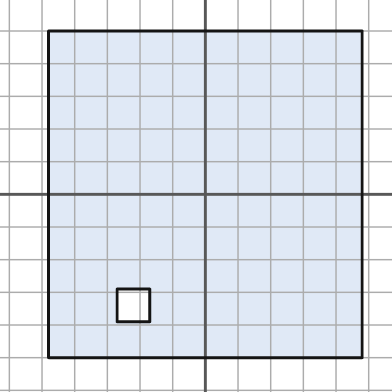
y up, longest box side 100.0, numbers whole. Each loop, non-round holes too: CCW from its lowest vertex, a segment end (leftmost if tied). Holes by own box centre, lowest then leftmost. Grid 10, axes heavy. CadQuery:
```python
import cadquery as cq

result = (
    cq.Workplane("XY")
    .moveTo(-48.0, -50.0)
    .lineTo(48.0, -50.0)
    .lineTo(48.0, 50.0)
    .lineTo(-48.0, 50.0)
    .close()
    .moveTo(-27.0, -39.0)
    .lineTo(-17.0, -39.0)
    .lineTo(-17.0, -29.0)
    .lineTo(-27.0, -29.0)
    .close()
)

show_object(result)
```